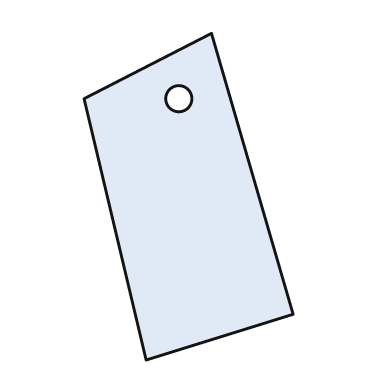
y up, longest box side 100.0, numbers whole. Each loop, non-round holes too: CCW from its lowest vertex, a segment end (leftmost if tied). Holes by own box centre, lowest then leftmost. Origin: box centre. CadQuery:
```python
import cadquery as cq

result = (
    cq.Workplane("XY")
    .moveTo(-13.0, -50.0)
    .lineTo(32.0, -36.0)
    .lineTo(7.0, 50.0)
    .lineTo(-32.0, 30.0)
    .close()
    .moveTo(-3.0, 30.0)
    .circle(4.0)
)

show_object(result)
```